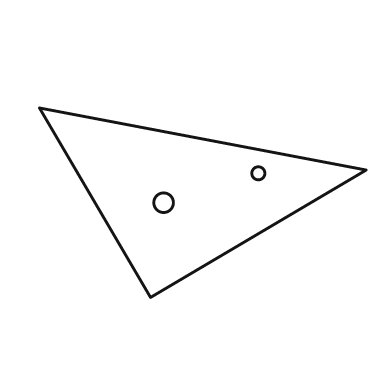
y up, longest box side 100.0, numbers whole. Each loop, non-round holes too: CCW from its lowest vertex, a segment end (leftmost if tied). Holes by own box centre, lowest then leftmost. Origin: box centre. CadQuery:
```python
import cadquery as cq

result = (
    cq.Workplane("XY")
    .moveTo(-16.0, -29.0)
    .lineTo(50.0, 10.0)
    .lineTo(-50.0, 29.0)
    .close()
    .moveTo(-12.0, 0.0)
    .circle(3.0)
    .moveTo(17.0, 9.0)
    .circle(2.0)
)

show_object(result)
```